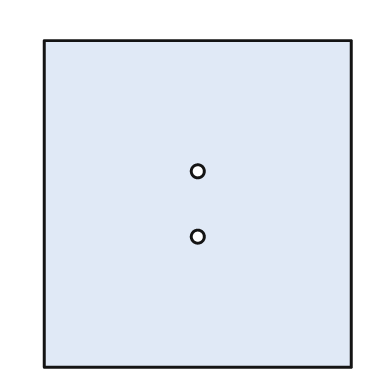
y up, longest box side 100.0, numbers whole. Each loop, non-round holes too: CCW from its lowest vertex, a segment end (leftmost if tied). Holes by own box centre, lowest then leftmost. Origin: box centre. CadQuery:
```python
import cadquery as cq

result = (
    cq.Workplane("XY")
    .moveTo(-47.0, -50.0)
    .lineTo(47.0, -50.0)
    .lineTo(47.0, 50.0)
    .lineTo(-47.0, 50.0)
    .close()
    .moveTo(0.0, -10.0)
    .circle(2.0)
    .moveTo(0.0, 10.0)
    .circle(2.0)
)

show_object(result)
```